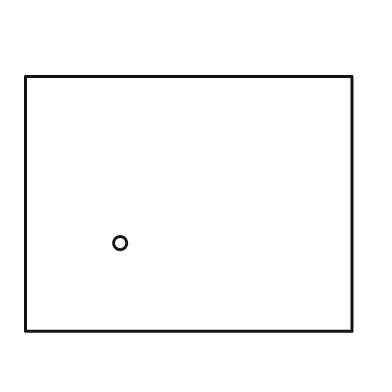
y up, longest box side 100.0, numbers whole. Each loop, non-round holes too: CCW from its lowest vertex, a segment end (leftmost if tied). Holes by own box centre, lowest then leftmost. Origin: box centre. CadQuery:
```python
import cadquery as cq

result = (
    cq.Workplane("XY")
    .moveTo(-50.0, -39.0)
    .lineTo(50.0, -39.0)
    .lineTo(50.0, 39.0)
    .lineTo(-50.0, 39.0)
    .close()
    .moveTo(-21.0, -12.0)
    .circle(2.0)
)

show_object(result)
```